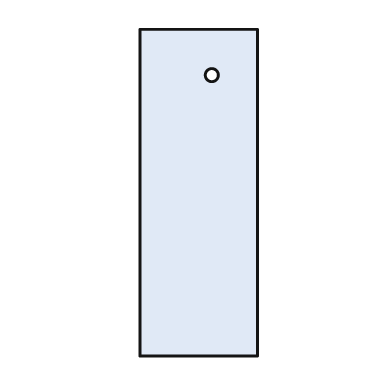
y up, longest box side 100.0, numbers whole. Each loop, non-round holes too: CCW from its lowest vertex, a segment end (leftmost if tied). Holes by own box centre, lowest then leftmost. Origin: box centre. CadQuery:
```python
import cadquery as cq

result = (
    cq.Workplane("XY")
    .moveTo(-18.0, -50.0)
    .lineTo(18.0, -50.0)
    .lineTo(18.0, 50.0)
    .lineTo(-18.0, 50.0)
    .close()
    .moveTo(4.0, 36.0)
    .circle(2.0)
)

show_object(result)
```